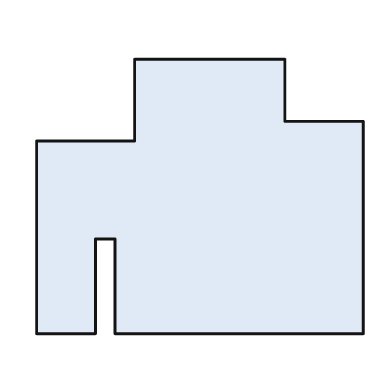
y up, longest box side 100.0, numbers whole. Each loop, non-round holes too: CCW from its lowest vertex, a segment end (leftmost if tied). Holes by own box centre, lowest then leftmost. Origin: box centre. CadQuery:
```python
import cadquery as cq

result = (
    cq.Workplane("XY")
    .moveTo(-50.0, -42.0)
    .lineTo(-32.0, -42.0)
    .lineTo(-32.0, -13.0)
    .lineTo(-26.0, -13.0)
    .lineTo(-26.0, -42.0)
    .lineTo(50.0, -42.0)
    .lineTo(50.0, 23.0)
    .lineTo(26.0, 23.0)
    .lineTo(26.0, 42.0)
    .lineTo(-20.0, 42.0)
    .lineTo(-20.0, 17.0)
    .lineTo(-50.0, 17.0)
    .close()
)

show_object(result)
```